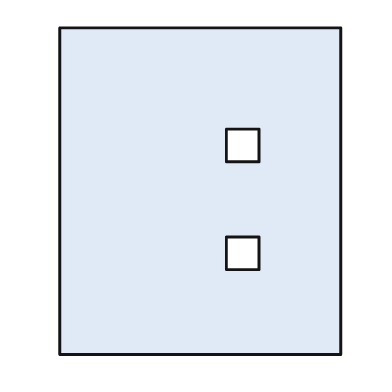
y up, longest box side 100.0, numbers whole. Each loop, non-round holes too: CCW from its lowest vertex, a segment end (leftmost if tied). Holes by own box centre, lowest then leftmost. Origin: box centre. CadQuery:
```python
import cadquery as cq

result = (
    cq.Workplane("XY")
    .moveTo(-43.0, -50.0)
    .lineTo(43.0, -50.0)
    .lineTo(43.0, 50.0)
    .lineTo(-43.0, 50.0)
    .close()
    .moveTo(8.0, -24.0)
    .lineTo(18.0, -24.0)
    .lineTo(18.0, -14.0)
    .lineTo(8.0, -14.0)
    .close()
    .moveTo(8.0, 9.0)
    .lineTo(18.0, 9.0)
    .lineTo(18.0, 19.0)
    .lineTo(8.0, 19.0)
    .close()
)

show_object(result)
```